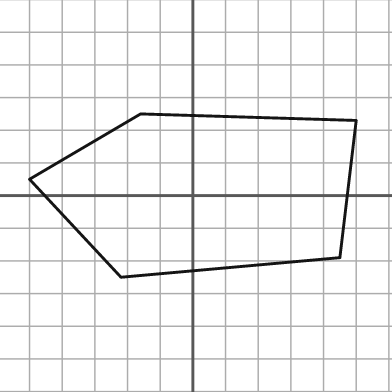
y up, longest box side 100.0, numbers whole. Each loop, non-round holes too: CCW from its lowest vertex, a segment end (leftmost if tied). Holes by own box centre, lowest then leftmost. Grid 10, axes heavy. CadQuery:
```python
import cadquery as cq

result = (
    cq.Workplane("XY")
    .moveTo(-22.0, -25.0)
    .lineTo(45.0, -19.0)
    .lineTo(50.0, 23.0)
    .lineTo(-16.0, 25.0)
    .lineTo(-50.0, 5.0)
    .close()
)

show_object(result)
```